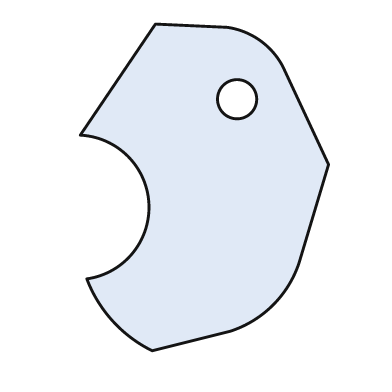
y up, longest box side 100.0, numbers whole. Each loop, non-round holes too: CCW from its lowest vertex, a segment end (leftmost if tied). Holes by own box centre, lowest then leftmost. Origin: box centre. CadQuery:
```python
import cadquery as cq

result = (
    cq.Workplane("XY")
    .moveTo(-16.0, -50.0)
    .lineTo(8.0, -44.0)
    .threePointArc((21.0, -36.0), (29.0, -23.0))
    .lineTo(38.0, 7.0)
    .lineTo(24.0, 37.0)
    .threePointArc((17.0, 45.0), (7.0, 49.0))
    .lineTo(-15.0, 50.0)
    .lineTo(-38.0, 16.0)
    .threePointArc((-17.0, -5.0), (-36.0, -28.0))
    .threePointArc((-28.0, -41.0), (-16.0, -50.0))
    .close()
    .moveTo(10.0, 27.0)
    .circle(6.0)
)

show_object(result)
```